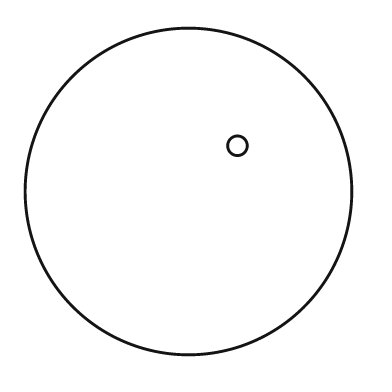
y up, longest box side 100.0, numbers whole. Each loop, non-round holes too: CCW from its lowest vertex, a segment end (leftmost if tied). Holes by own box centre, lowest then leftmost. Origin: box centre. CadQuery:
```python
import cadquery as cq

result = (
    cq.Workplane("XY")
    .moveTo(0.0, 0.0)
    .circle(50.0)
    .moveTo(15.0, 14.0)
    .circle(3.0)
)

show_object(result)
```